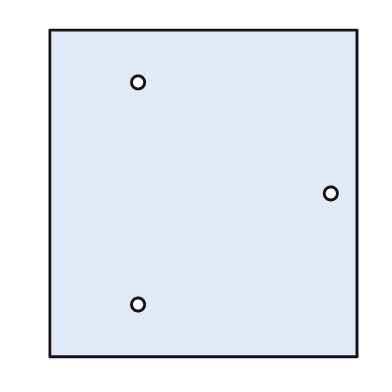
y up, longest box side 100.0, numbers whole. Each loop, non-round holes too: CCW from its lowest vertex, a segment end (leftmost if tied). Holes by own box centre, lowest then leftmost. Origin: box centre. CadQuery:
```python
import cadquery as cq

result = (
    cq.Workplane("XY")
    .moveTo(-47.0, -50.0)
    .lineTo(47.0, -50.0)
    .lineTo(47.0, 50.0)
    .lineTo(-47.0, 50.0)
    .close()
    .moveTo(-20.0, -34.0)
    .circle(2.0)
    .moveTo(39.0, 0.0)
    .circle(2.0)
    .moveTo(-20.0, 34.0)
    .circle(2.0)
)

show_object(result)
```